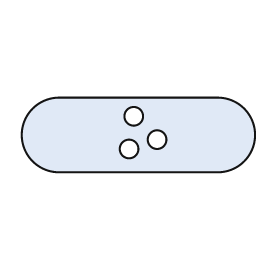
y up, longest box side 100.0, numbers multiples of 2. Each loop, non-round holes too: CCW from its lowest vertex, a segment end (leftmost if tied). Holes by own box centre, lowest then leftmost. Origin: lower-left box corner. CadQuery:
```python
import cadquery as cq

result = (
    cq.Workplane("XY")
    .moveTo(16.0, 0.0)
    .lineTo(84.0, 0.0)
    .threePointArc((100.0, 16.0), (84.0, 32.0))
    .lineTo(16.0, 32.0)
    .threePointArc((0.0, 16.0), (16.0, 0.0))
    .close()
    .moveTo(46.0, 10.0)
    .circle(4.0)
    .moveTo(58.0, 14.0)
    .circle(4.0)
    .moveTo(48.0, 24.0)
    .circle(4.0)
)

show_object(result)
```